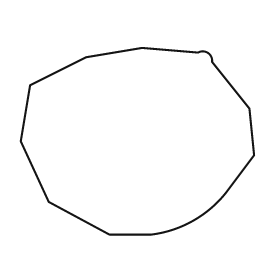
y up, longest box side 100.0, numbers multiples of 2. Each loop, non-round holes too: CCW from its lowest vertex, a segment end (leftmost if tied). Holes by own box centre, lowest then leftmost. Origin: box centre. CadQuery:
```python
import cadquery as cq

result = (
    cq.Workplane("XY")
    .moveTo(-12.0, -40.0)
    .lineTo(6.0, -40.0)
    .threePointArc((24.0, -34.0), (38.0, -22.0))
    .lineTo(50.0, -6.0)
    .lineTo(48.0, 14.0)
    .lineTo(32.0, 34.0)
    .threePointArc((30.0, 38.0), (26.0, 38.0))
    .lineTo(2.0, 40.0)
    .lineTo(-22.0, 36.0)
    .lineTo(-46.0, 24.0)
    .lineTo(-50.0, 0.0)
    .lineTo(-38.0, -26.0)
    .close()
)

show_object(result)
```